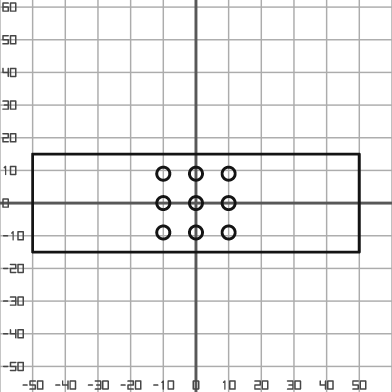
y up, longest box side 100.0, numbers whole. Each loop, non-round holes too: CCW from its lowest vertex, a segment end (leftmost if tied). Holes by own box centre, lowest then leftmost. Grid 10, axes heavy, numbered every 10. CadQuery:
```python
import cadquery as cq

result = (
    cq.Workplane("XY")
    .moveTo(-50.0, -15.0)
    .lineTo(50.0, -15.0)
    .lineTo(50.0, 15.0)
    .lineTo(-50.0, 15.0)
    .close()
    .moveTo(-10.0, -9.0)
    .circle(2.0)
    .moveTo(0.0, -9.0)
    .circle(2.0)
    .moveTo(10.0, -9.0)
    .circle(2.0)
    .moveTo(-10.0, 0.0)
    .circle(2.0)
    .moveTo(0.0, 0.0)
    .circle(2.0)
    .moveTo(10.0, 0.0)
    .circle(2.0)
    .moveTo(-10.0, 9.0)
    .circle(2.0)
    .moveTo(0.0, 9.0)
    .circle(2.0)
    .moveTo(10.0, 9.0)
    .circle(2.0)
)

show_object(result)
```